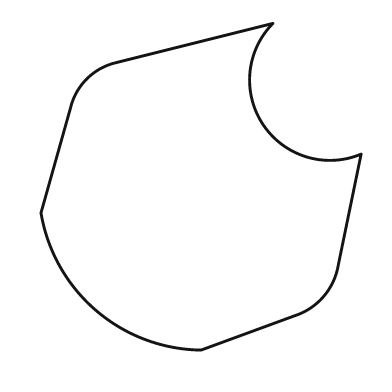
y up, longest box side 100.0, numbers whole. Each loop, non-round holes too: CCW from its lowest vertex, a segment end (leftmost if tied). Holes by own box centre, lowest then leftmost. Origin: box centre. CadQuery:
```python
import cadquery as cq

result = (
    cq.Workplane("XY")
    .moveTo(0.0, -50.0)
    .lineTo(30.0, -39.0)
    .threePointArc((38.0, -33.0), (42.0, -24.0))
    .lineTo(49.0, 10.0)
    .threePointArc((19.0, 19.0), (22.0, 50.0))
    .lineTo(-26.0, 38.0)
    .threePointArc((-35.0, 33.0), (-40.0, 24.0))
    .lineTo(-49.0, -8.0)
    .threePointArc((-32.0, -38.0), (0.0, -50.0))
    .close()
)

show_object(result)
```